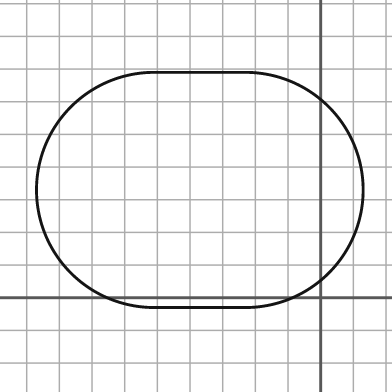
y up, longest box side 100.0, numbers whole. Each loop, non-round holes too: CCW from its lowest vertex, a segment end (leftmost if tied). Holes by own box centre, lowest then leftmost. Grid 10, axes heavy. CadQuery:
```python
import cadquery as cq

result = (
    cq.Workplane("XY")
    .moveTo(-51.0, -3.0)
    .lineTo(-23.0, -3.0)
    .threePointArc((13.0, 33.0), (-23.0, 69.0))
    .lineTo(-51.0, 69.0)
    .threePointArc((-87.0, 33.0), (-51.0, -3.0))
    .close()
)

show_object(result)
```